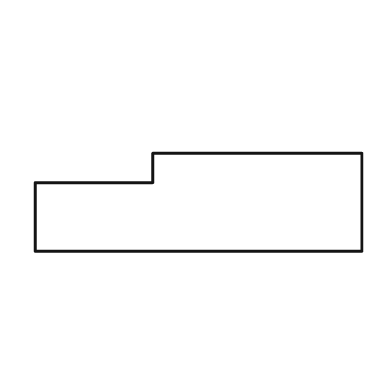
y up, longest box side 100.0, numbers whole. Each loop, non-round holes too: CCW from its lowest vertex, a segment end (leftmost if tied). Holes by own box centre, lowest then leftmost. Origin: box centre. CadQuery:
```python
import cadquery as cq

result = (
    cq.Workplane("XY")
    .moveTo(-50.0, -15.0)
    .lineTo(50.0, -15.0)
    .lineTo(50.0, 15.0)
    .lineTo(-14.0, 15.0)
    .lineTo(-14.0, 6.0)
    .lineTo(-50.0, 6.0)
    .close()
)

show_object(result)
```